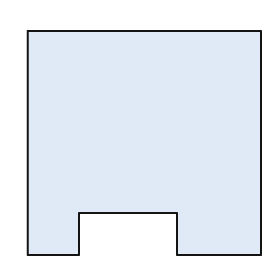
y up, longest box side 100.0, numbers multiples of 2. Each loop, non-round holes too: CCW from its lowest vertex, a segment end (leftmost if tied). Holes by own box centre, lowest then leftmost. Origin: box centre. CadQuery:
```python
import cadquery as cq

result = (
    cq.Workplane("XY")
    .moveTo(-50.0, -48.0)
    .lineTo(-28.0, -48.0)
    .lineTo(-28.0, -30.0)
    .lineTo(14.0, -30.0)
    .lineTo(14.0, -48.0)
    .lineTo(50.0, -48.0)
    .lineTo(50.0, 48.0)
    .lineTo(-50.0, 48.0)
    .close()
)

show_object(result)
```